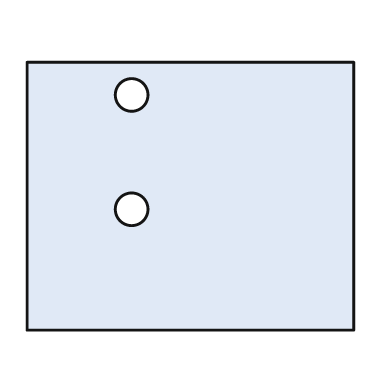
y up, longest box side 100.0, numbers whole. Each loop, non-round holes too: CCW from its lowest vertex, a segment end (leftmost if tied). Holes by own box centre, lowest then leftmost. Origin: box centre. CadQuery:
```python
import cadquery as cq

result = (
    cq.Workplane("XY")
    .moveTo(-50.0, -41.0)
    .lineTo(50.0, -41.0)
    .lineTo(50.0, 41.0)
    .lineTo(-50.0, 41.0)
    .close()
    .moveTo(-18.0, -4.0)
    .circle(5.0)
    .moveTo(-18.0, 31.0)
    .circle(5.0)
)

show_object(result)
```